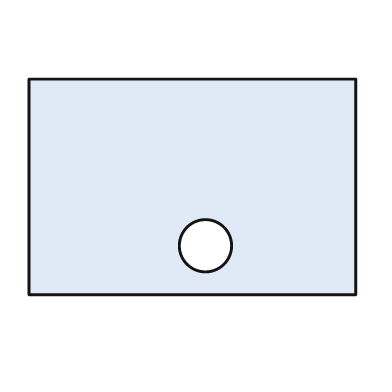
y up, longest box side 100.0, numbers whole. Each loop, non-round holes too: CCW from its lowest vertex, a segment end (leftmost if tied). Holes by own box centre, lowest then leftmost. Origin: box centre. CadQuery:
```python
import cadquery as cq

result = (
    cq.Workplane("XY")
    .moveTo(-50.0, -33.0)
    .lineTo(50.0, -33.0)
    .lineTo(50.0, 33.0)
    .lineTo(-50.0, 33.0)
    .close()
    .moveTo(4.0, -18.0)
    .circle(8.0)
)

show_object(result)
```